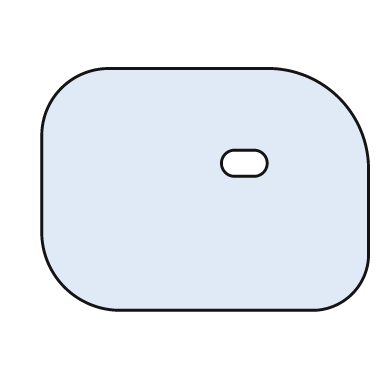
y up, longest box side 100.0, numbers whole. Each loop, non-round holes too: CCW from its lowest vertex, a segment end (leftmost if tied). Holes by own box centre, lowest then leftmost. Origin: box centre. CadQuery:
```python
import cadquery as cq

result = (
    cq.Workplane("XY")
    .moveTo(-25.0, -37.0)
    .lineTo(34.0, -37.0)
    .threePointArc((45.0, -32.0), (50.0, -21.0))
    .lineTo(50.0, 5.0)
    .threePointArc((41.0, 28.0), (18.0, 37.0))
    .lineTo(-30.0, 37.0)
    .threePointArc((-44.0, 31.0), (-50.0, 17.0))
    .lineTo(-50.0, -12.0)
    .threePointArc((-43.0, -30.0), (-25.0, -37.0))
    .close()
    .moveTo(9.0, 4.0)
    .lineTo(15.0, 4.0)
    .threePointArc((19.0, 8.0), (15.0, 12.0))
    .lineTo(9.0, 12.0)
    .threePointArc((5.0, 8.0), (9.0, 4.0))
    .close()
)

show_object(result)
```